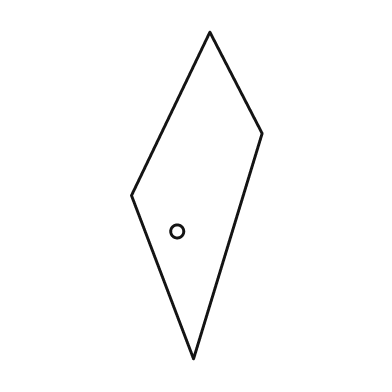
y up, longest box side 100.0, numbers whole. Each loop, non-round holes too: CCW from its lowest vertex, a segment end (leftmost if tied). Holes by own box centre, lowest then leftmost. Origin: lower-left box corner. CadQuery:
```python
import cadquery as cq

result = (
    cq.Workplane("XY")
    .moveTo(19.0, 0.0)
    .lineTo(40.0, 69.0)
    .lineTo(24.0, 100.0)
    .lineTo(0.0, 50.0)
    .close()
    .moveTo(14.0, 39.0)
    .circle(2.0)
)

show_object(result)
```